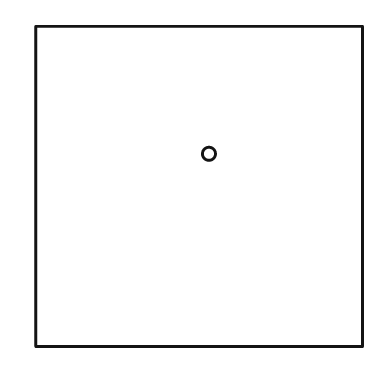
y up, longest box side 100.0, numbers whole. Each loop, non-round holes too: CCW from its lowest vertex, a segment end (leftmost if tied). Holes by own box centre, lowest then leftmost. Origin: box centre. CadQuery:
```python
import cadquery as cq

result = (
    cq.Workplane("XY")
    .moveTo(-50.0, -49.0)
    .lineTo(50.0, -49.0)
    .lineTo(50.0, 49.0)
    .lineTo(-50.0, 49.0)
    .close()
    .moveTo(3.0, 10.0)
    .circle(2.0)
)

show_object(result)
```